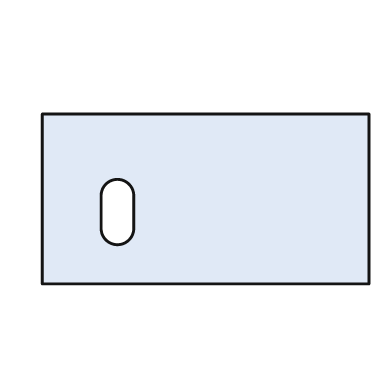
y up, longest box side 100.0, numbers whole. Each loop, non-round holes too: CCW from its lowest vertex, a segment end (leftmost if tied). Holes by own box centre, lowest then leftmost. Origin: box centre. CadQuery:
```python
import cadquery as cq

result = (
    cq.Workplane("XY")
    .moveTo(-50.0, -26.0)
    .lineTo(50.0, -26.0)
    .lineTo(50.0, 26.0)
    .lineTo(-50.0, 26.0)
    .close()
    .moveTo(-32.0, -9.0)
    .threePointArc((-27.0, -14.0), (-22.0, -9.0))
    .lineTo(-22.0, 1.0)
    .threePointArc((-27.0, 6.0), (-32.0, 1.0))
    .close()
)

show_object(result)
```